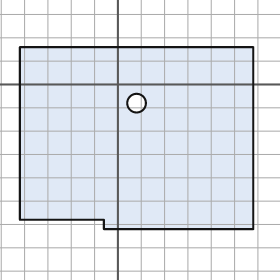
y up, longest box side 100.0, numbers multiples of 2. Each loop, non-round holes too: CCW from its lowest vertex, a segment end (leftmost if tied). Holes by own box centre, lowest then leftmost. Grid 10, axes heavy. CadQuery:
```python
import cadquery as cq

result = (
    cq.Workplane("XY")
    .moveTo(-6.0, -62.0)
    .lineTo(58.0, -62.0)
    .lineTo(58.0, 16.0)
    .lineTo(-42.0, 16.0)
    .lineTo(-42.0, -58.0)
    .lineTo(-6.0, -58.0)
    .close()
    .moveTo(8.0, -8.0)
    .circle(4.0)
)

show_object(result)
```